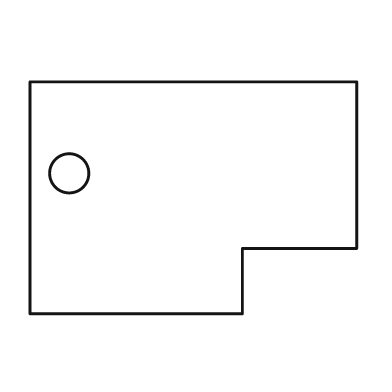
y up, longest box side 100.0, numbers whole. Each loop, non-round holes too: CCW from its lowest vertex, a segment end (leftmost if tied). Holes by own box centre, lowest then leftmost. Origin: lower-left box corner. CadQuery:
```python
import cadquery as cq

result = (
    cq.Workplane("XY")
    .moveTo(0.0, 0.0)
    .lineTo(65.0, 0.0)
    .lineTo(65.0, 20.0)
    .lineTo(100.0, 20.0)
    .lineTo(100.0, 71.0)
    .lineTo(0.0, 71.0)
    .close()
    .moveTo(12.0, 43.0)
    .circle(6.0)
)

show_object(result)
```